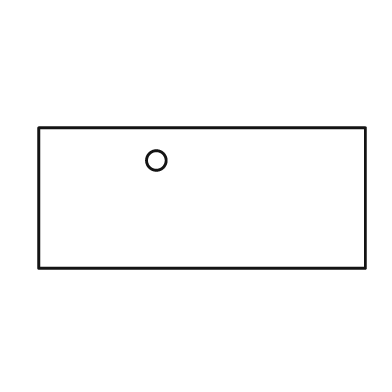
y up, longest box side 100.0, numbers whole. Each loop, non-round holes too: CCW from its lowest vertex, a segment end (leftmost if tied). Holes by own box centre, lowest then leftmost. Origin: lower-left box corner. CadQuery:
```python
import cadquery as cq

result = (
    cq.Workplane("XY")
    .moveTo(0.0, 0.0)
    .lineTo(100.0, 0.0)
    .lineTo(100.0, 43.0)
    .lineTo(0.0, 43.0)
    .close()
    .moveTo(36.0, 33.0)
    .circle(3.0)
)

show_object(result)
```